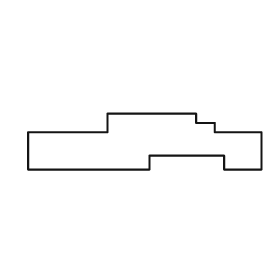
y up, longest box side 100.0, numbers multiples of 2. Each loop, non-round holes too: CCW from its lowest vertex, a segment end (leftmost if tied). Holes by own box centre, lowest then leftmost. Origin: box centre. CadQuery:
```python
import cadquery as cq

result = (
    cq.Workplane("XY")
    .moveTo(-50.0, -12.0)
    .lineTo(2.0, -12.0)
    .lineTo(2.0, -6.0)
    .lineTo(34.0, -6.0)
    .lineTo(34.0, -12.0)
    .lineTo(50.0, -12.0)
    .lineTo(50.0, 4.0)
    .lineTo(30.0, 4.0)
    .lineTo(30.0, 8.0)
    .lineTo(22.0, 8.0)
    .lineTo(22.0, 12.0)
    .lineTo(-16.0, 12.0)
    .lineTo(-16.0, 4.0)
    .lineTo(-50.0, 4.0)
    .close()
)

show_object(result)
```